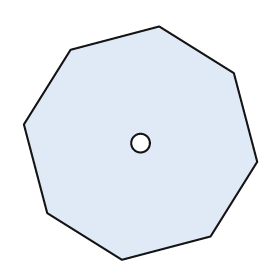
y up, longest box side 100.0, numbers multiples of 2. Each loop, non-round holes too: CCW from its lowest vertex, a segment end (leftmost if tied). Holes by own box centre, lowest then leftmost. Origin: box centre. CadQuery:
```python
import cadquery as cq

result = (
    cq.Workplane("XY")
    .moveTo(-8.0, -50.0)
    .lineTo(30.0, -40.0)
    .lineTo(50.0, -8.0)
    .lineTo(40.0, 30.0)
    .lineTo(8.0, 50.0)
    .lineTo(-30.0, 40.0)
    .lineTo(-50.0, 8.0)
    .lineTo(-40.0, -30.0)
    .close()
    .moveTo(0.0, 0.0)
    .circle(4.0)
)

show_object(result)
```